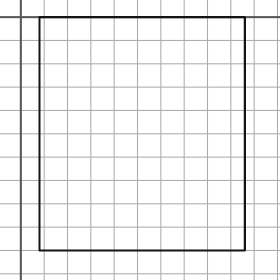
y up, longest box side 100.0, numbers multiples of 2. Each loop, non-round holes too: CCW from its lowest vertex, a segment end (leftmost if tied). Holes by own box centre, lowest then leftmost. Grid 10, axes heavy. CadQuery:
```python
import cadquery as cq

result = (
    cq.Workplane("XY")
    .moveTo(8.0, -100.0)
    .lineTo(96.0, -100.0)
    .lineTo(96.0, 0.0)
    .lineTo(8.0, 0.0)
    .close()
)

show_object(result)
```